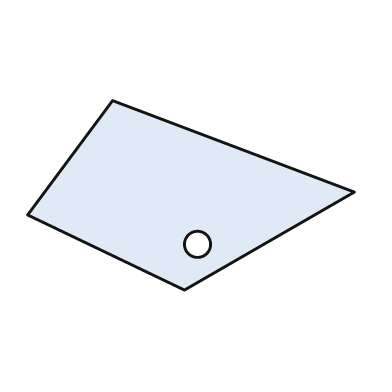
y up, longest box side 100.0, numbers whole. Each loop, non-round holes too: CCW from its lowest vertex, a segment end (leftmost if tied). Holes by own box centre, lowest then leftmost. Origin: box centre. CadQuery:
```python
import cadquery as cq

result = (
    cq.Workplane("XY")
    .moveTo(-2.0, -29.0)
    .lineTo(50.0, 1.0)
    .lineTo(-24.0, 29.0)
    .lineTo(-50.0, -6.0)
    .close()
    .moveTo(2.0, -15.0)
    .circle(4.0)
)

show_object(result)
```